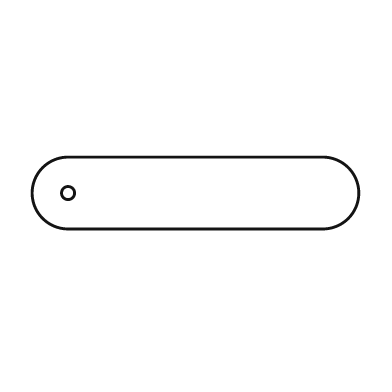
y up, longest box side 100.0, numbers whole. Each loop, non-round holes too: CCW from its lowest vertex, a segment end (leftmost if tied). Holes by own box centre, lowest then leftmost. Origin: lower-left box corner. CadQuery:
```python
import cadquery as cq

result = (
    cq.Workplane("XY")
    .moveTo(11.0, 0.0)
    .lineTo(89.0, 0.0)
    .threePointArc((100.0, 11.0), (89.0, 22.0))
    .lineTo(11.0, 22.0)
    .threePointArc((0.0, 11.0), (11.0, 0.0))
    .close()
    .moveTo(11.0, 11.0)
    .circle(2.0)
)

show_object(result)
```